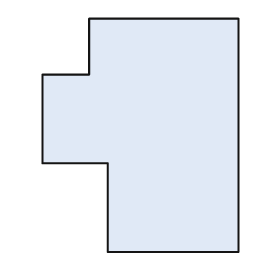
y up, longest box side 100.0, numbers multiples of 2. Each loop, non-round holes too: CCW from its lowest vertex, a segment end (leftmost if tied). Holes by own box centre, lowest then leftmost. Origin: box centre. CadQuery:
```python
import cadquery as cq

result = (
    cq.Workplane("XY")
    .moveTo(-14.0, -50.0)
    .lineTo(42.0, -50.0)
    .lineTo(42.0, 50.0)
    .lineTo(-22.0, 50.0)
    .lineTo(-22.0, 26.0)
    .lineTo(-42.0, 26.0)
    .lineTo(-42.0, -12.0)
    .lineTo(-14.0, -12.0)
    .close()
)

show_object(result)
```